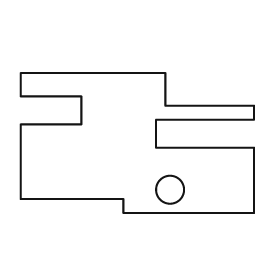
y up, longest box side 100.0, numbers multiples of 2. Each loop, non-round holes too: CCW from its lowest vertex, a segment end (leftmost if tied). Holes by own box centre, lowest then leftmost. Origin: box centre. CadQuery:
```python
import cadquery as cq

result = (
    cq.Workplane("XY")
    .moveTo(-6.0, -30.0)
    .lineTo(50.0, -30.0)
    .lineTo(50.0, -2.0)
    .lineTo(8.0, -2.0)
    .lineTo(8.0, 10.0)
    .lineTo(50.0, 10.0)
    .lineTo(50.0, 16.0)
    .lineTo(12.0, 16.0)
    .lineTo(12.0, 30.0)
    .lineTo(-50.0, 30.0)
    .lineTo(-50.0, 20.0)
    .lineTo(-24.0, 20.0)
    .lineTo(-24.0, 8.0)
    .lineTo(-50.0, 8.0)
    .lineTo(-50.0, -24.0)
    .lineTo(-6.0, -24.0)
    .close()
    .moveTo(14.0, -20.0)
    .circle(6.0)
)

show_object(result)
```